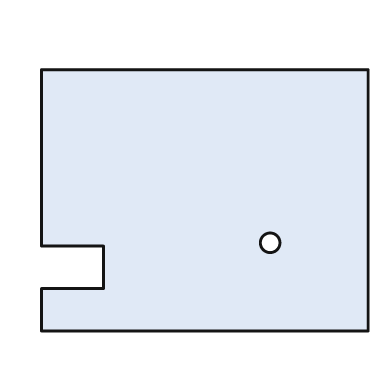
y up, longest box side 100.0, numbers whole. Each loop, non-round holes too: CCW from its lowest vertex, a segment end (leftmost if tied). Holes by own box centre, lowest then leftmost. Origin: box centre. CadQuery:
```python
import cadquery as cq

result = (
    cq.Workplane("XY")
    .moveTo(-50.0, -40.0)
    .lineTo(50.0, -40.0)
    .lineTo(50.0, 40.0)
    .lineTo(-50.0, 40.0)
    .lineTo(-50.0, -14.0)
    .lineTo(-31.0, -14.0)
    .lineTo(-31.0, -27.0)
    .lineTo(-50.0, -27.0)
    .close()
    .moveTo(20.0, -13.0)
    .circle(3.0)
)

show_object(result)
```